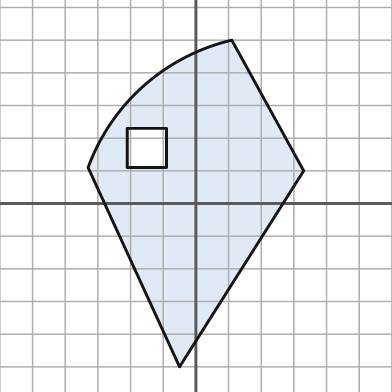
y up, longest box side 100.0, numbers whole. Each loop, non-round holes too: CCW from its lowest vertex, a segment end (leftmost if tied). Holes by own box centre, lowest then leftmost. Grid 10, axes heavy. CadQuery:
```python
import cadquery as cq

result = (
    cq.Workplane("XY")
    .moveTo(-5.0, -50.0)
    .lineTo(33.0, 10.0)
    .lineTo(11.0, 50.0)
    .threePointArc((-16.0, 36.0), (-33.0, 11.0))
    .close()
    .moveTo(-21.0, 11.0)
    .lineTo(-9.0, 11.0)
    .lineTo(-9.0, 23.0)
    .lineTo(-21.0, 23.0)
    .close()
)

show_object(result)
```